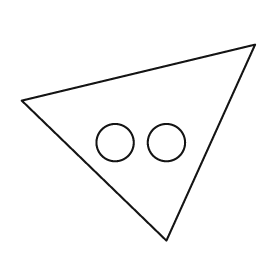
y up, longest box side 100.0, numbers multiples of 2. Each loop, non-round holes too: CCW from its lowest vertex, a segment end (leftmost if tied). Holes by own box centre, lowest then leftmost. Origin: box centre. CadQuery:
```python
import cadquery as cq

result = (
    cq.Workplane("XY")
    .moveTo(12.0, -42.0)
    .lineTo(50.0, 42.0)
    .lineTo(-50.0, 18.0)
    .close()
    .moveTo(-10.0, 0.0)
    .circle(8.0)
    .moveTo(12.0, 0.0)
    .circle(8.0)
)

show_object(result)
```